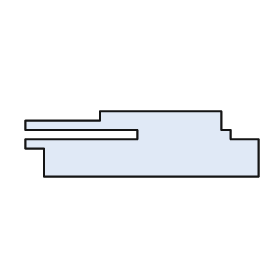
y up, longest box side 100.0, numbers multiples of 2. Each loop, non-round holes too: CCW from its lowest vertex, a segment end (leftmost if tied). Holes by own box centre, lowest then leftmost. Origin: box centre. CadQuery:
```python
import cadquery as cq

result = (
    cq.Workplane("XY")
    .moveTo(-42.0, -14.0)
    .lineTo(50.0, -14.0)
    .lineTo(50.0, 2.0)
    .lineTo(38.0, 2.0)
    .lineTo(38.0, 6.0)
    .lineTo(34.0, 6.0)
    .lineTo(34.0, 14.0)
    .lineTo(-18.0, 14.0)
    .lineTo(-18.0, 10.0)
    .lineTo(-50.0, 10.0)
    .lineTo(-50.0, 6.0)
    .lineTo(-2.0, 6.0)
    .lineTo(-2.0, 2.0)
    .lineTo(-50.0, 2.0)
    .lineTo(-50.0, -2.0)
    .lineTo(-42.0, -2.0)
    .close()
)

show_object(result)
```